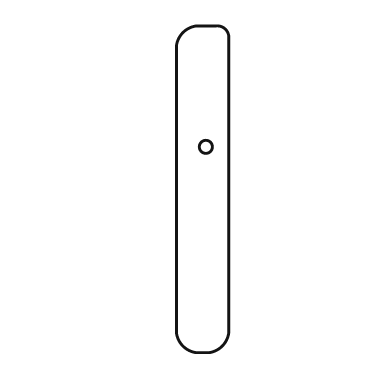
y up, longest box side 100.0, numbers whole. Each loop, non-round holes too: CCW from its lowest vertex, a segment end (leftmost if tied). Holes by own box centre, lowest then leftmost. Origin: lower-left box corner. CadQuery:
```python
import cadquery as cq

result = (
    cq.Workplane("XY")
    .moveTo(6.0, 0.0)
    .lineTo(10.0, 0.0)
    .threePointArc((14.0, 2.0), (16.0, 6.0))
    .lineTo(16.0, 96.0)
    .threePointArc((15.0, 99.0), (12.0, 100.0))
    .lineTo(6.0, 100.0)
    .threePointArc((2.0, 98.0), (0.0, 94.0))
    .lineTo(0.0, 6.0)
    .threePointArc((2.0, 2.0), (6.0, 0.0))
    .close()
    .moveTo(9.0, 63.0)
    .circle(2.0)
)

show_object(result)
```